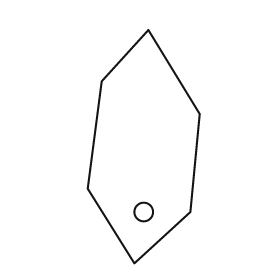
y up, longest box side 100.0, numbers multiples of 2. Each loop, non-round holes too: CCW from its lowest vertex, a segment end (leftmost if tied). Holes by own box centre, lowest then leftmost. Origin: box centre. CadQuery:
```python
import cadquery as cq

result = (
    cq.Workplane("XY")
    .moveTo(-4.0, -50.0)
    .lineTo(20.0, -28.0)
    .lineTo(24.0, 14.0)
    .lineTo(2.0, 50.0)
    .lineTo(-18.0, 28.0)
    .lineTo(-24.0, -18.0)
    .close()
    .moveTo(0.0, -28.0)
    .circle(4.0)
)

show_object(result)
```